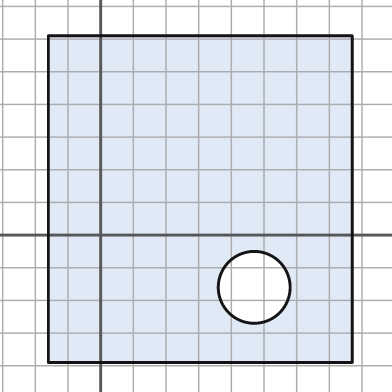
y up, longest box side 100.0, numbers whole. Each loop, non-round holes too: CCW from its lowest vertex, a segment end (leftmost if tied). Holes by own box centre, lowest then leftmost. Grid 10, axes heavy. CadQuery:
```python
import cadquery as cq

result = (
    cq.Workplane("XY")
    .moveTo(-16.0, -39.0)
    .lineTo(77.0, -39.0)
    .lineTo(77.0, 61.0)
    .lineTo(-16.0, 61.0)
    .close()
    .moveTo(47.0, -16.0)
    .circle(11.0)
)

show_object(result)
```